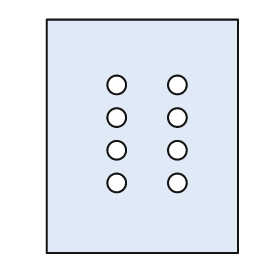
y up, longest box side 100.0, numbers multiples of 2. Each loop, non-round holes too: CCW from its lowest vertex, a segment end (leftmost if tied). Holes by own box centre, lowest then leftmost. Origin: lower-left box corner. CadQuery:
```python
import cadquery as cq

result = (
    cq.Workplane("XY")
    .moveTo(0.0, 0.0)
    .lineTo(82.0, 0.0)
    .lineTo(82.0, 100.0)
    .lineTo(0.0, 100.0)
    .close()
    .moveTo(30.0, 30.0)
    .circle(4.0)
    .moveTo(56.0, 30.0)
    .circle(4.0)
    .moveTo(30.0, 44.0)
    .circle(4.0)
    .moveTo(56.0, 44.0)
    .circle(4.0)
    .moveTo(30.0, 58.0)
    .circle(4.0)
    .moveTo(56.0, 58.0)
    .circle(4.0)
    .moveTo(30.0, 72.0)
    .circle(4.0)
    .moveTo(56.0, 72.0)
    .circle(4.0)
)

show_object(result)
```